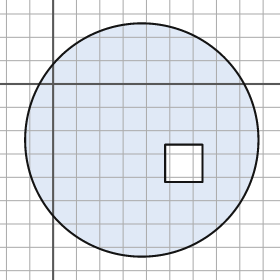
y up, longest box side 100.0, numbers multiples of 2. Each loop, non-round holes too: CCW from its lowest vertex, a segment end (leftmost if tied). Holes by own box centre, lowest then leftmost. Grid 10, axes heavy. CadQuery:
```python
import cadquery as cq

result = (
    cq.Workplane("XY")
    .moveTo(38.0, -24.0)
    .circle(50.0)
    .moveTo(48.0, -42.0)
    .lineTo(64.0, -42.0)
    .lineTo(64.0, -26.0)
    .lineTo(48.0, -26.0)
    .close()
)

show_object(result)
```